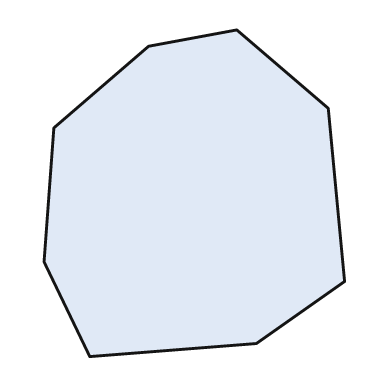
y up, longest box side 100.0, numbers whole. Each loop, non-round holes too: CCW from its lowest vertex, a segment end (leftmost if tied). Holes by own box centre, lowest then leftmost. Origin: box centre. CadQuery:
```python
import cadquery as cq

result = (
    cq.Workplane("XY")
    .moveTo(-32.0, -50.0)
    .lineTo(19.0, -46.0)
    .lineTo(46.0, -27.0)
    .lineTo(41.0, 26.0)
    .lineTo(13.0, 50.0)
    .lineTo(-14.0, 45.0)
    .lineTo(-43.0, 20.0)
    .lineTo(-46.0, -21.0)
    .close()
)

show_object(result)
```